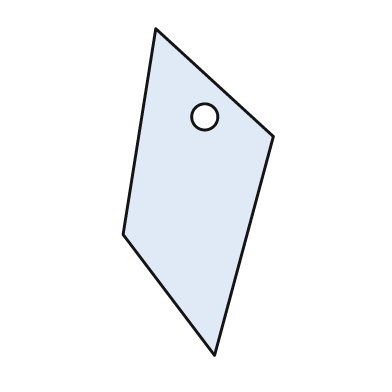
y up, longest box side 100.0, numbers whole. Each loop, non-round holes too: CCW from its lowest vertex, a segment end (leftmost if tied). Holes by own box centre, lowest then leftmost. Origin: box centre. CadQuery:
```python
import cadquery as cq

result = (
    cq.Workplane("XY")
    .moveTo(5.0, -50.0)
    .lineTo(23.0, 17.0)
    .lineTo(-13.0, 50.0)
    .lineTo(-23.0, -13.0)
    .close()
    .moveTo(2.0, 23.0)
    .circle(4.0)
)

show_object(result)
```